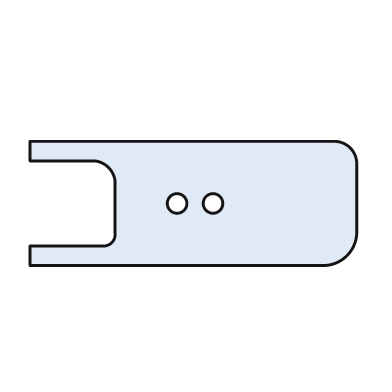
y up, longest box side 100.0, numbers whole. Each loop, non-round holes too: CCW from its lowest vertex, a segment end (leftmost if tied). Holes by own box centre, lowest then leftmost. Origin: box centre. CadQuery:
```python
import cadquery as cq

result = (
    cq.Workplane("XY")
    .moveTo(-50.0, -19.0)
    .lineTo(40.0, -19.0)
    .threePointArc((47.0, -16.0), (50.0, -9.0))
    .lineTo(50.0, 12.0)
    .threePointArc((48.0, 17.0), (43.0, 19.0))
    .lineTo(-50.0, 19.0)
    .lineTo(-50.0, 13.0)
    .lineTo(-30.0, 13.0)
    .threePointArc((-26.0, 11.0), (-24.0, 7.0))
    .lineTo(-24.0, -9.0)
    .threePointArc((-25.0, -12.0), (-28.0, -13.0))
    .lineTo(-50.0, -13.0)
    .close()
    .moveTo(-5.0, 0.0)
    .circle(3.0)
    .moveTo(6.0, 0.0)
    .circle(3.0)
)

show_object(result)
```